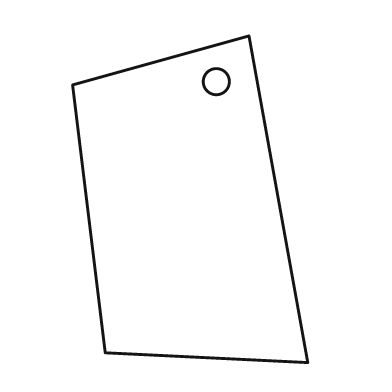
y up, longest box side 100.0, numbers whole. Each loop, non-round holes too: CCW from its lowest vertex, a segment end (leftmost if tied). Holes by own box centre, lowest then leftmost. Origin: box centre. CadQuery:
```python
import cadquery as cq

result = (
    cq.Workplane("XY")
    .moveTo(36.0, -50.0)
    .lineTo(18.0, 50.0)
    .lineTo(-36.0, 35.0)
    .lineTo(-26.0, -47.0)
    .close()
    .moveTo(8.0, 36.0)
    .circle(4.0)
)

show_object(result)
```